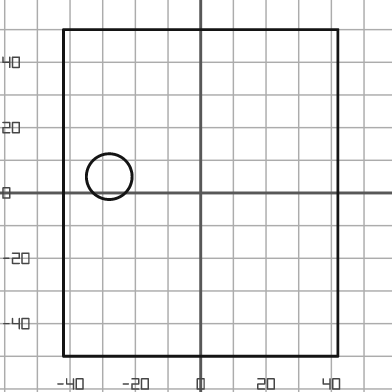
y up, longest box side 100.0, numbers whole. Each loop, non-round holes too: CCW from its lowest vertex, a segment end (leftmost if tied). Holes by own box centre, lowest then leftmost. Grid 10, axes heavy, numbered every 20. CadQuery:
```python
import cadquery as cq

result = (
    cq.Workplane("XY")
    .moveTo(-42.0, -50.0)
    .lineTo(42.0, -50.0)
    .lineTo(42.0, 50.0)
    .lineTo(-42.0, 50.0)
    .close()
    .moveTo(-28.0, 5.0)
    .circle(7.0)
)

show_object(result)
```